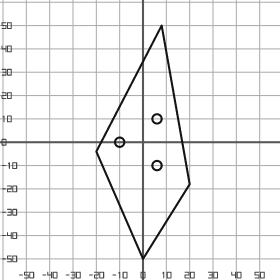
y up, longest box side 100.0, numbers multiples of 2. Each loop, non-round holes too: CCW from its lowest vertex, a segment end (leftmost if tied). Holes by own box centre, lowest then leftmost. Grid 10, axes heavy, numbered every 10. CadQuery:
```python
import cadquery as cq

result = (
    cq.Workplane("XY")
    .moveTo(0.0, -50.0)
    .lineTo(20.0, -18.0)
    .lineTo(8.0, 50.0)
    .lineTo(-20.0, -4.0)
    .close()
    .moveTo(6.0, -10.0)
    .circle(2.0)
    .moveTo(-10.0, 0.0)
    .circle(2.0)
    .moveTo(6.0, 10.0)
    .circle(2.0)
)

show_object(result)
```